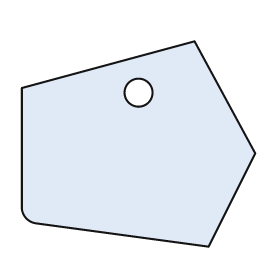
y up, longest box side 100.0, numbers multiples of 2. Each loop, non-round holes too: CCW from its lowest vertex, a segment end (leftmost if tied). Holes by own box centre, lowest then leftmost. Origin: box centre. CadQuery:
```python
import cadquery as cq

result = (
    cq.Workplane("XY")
    .moveTo(30.0, -44.0)
    .lineTo(50.0, -4.0)
    .lineTo(24.0, 44.0)
    .lineTo(-50.0, 24.0)
    .lineTo(-50.0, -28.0)
    .threePointArc((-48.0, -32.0), (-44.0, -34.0))
    .close()
    .moveTo(0.0, 22.0)
    .circle(6.0)
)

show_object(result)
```